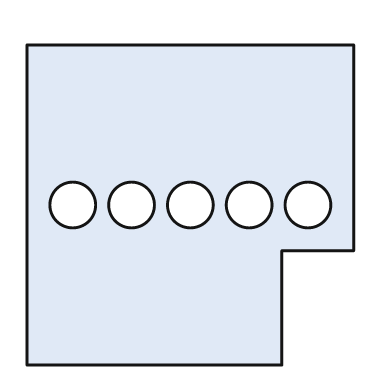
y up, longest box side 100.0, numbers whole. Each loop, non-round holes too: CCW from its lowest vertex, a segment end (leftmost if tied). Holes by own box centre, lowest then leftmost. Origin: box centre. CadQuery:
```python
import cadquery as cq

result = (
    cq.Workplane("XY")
    .moveTo(-50.0, -49.0)
    .lineTo(28.0, -49.0)
    .lineTo(28.0, -14.0)
    .lineTo(50.0, -14.0)
    .lineTo(50.0, 49.0)
    .lineTo(-50.0, 49.0)
    .close()
    .moveTo(-36.0, 0.0)
    .circle(7.0)
    .moveTo(-18.0, 0.0)
    .circle(7.0)
    .moveTo(0.0, 0.0)
    .circle(7.0)
    .moveTo(18.0, 0.0)
    .circle(7.0)
    .moveTo(36.0, 0.0)
    .circle(7.0)
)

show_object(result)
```